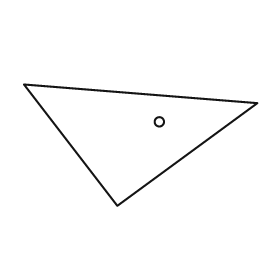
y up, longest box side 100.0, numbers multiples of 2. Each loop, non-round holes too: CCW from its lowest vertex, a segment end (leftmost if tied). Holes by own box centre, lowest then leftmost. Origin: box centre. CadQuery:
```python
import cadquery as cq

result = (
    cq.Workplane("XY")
    .moveTo(-10.0, -26.0)
    .lineTo(50.0, 18.0)
    .lineTo(-50.0, 26.0)
    .close()
    .moveTo(8.0, 10.0)
    .circle(2.0)
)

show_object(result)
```